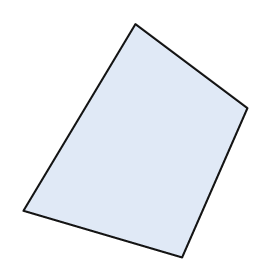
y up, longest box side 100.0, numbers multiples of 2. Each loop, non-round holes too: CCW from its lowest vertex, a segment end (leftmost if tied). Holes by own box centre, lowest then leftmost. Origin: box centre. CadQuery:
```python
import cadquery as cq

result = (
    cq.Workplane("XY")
    .moveTo(20.0, -50.0)
    .lineTo(48.0, 14.0)
    .lineTo(0.0, 50.0)
    .lineTo(-48.0, -30.0)
    .close()
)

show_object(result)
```